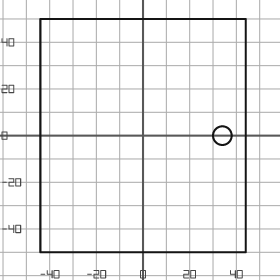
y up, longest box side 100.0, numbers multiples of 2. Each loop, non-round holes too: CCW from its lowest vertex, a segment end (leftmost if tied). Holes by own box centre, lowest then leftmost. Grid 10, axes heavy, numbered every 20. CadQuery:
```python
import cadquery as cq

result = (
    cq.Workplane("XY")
    .moveTo(-44.0, -50.0)
    .lineTo(44.0, -50.0)
    .lineTo(44.0, 50.0)
    .lineTo(-44.0, 50.0)
    .close()
    .moveTo(34.0, 0.0)
    .circle(4.0)
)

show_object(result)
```